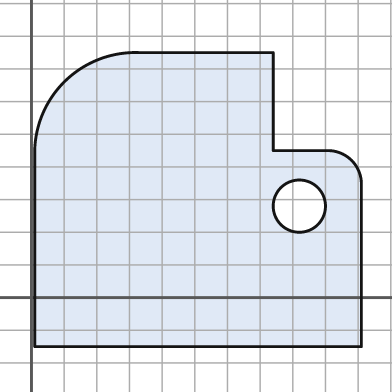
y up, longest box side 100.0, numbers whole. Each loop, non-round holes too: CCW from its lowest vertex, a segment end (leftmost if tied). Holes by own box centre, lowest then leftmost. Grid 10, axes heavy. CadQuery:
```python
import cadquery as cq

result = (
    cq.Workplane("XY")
    .moveTo(1.0, -15.0)
    .lineTo(101.0, -15.0)
    .lineTo(101.0, 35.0)
    .threePointArc((98.0, 42.0), (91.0, 45.0))
    .lineTo(74.0, 45.0)
    .lineTo(74.0, 75.0)
    .lineTo(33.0, 75.0)
    .threePointArc((10.0, 66.0), (1.0, 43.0))
    .close()
    .moveTo(82.0, 28.0)
    .circle(8.0)
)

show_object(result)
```